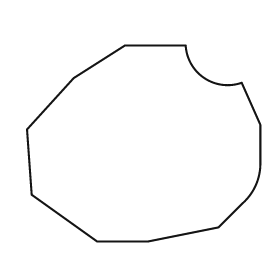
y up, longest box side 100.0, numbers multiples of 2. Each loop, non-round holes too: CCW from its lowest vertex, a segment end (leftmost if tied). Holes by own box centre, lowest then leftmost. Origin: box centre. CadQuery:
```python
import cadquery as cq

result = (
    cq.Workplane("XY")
    .moveTo(-20.0, -42.0)
    .lineTo(2.0, -42.0)
    .lineTo(32.0, -36.0)
    .lineTo(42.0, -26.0)
    .threePointArc((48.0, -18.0), (50.0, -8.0))
    .lineTo(50.0, 8.0)
    .lineTo(42.0, 26.0)
    .threePointArc((26.0, 28.0), (18.0, 42.0))
    .lineTo(-8.0, 42.0)
    .lineTo(-30.0, 28.0)
    .lineTo(-50.0, 6.0)
    .lineTo(-48.0, -22.0)
    .close()
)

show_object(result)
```